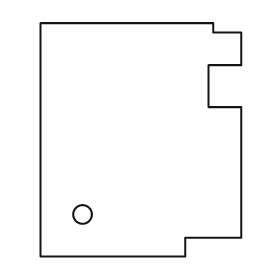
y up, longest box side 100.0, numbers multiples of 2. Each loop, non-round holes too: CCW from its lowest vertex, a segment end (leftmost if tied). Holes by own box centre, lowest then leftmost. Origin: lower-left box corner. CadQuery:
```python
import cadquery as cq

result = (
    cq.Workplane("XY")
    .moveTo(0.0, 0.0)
    .lineTo(62.0, 0.0)
    .lineTo(62.0, 8.0)
    .lineTo(86.0, 8.0)
    .lineTo(86.0, 64.0)
    .lineTo(72.0, 64.0)
    .lineTo(72.0, 82.0)
    .lineTo(86.0, 82.0)
    .lineTo(86.0, 96.0)
    .lineTo(74.0, 96.0)
    .lineTo(74.0, 100.0)
    .lineTo(0.0, 100.0)
    .close()
    .moveTo(18.0, 18.0)
    .circle(4.0)
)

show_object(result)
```